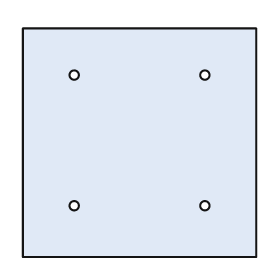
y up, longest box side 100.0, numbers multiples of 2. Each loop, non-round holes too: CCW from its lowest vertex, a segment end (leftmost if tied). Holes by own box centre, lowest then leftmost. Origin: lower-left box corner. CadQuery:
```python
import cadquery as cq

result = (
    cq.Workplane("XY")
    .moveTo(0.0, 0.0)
    .lineTo(100.0, 0.0)
    .lineTo(100.0, 98.0)
    .lineTo(0.0, 98.0)
    .close()
    .moveTo(22.0, 22.0)
    .circle(2.0)
    .moveTo(78.0, 22.0)
    .circle(2.0)
    .moveTo(22.0, 78.0)
    .circle(2.0)
    .moveTo(78.0, 78.0)
    .circle(2.0)
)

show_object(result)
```